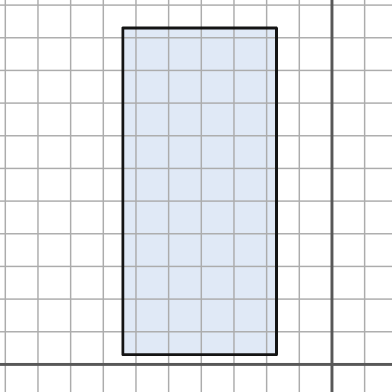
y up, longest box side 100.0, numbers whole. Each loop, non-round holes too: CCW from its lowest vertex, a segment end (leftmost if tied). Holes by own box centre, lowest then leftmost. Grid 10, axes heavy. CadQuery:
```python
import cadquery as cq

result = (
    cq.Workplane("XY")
    .moveTo(-64.0, 3.0)
    .lineTo(-17.0, 3.0)
    .lineTo(-17.0, 103.0)
    .lineTo(-64.0, 103.0)
    .close()
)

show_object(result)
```